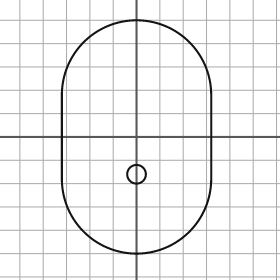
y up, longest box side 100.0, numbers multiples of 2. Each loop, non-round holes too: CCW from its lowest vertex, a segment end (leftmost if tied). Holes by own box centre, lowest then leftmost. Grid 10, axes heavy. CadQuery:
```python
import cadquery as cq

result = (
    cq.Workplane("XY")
    .moveTo(-32.0, -18.0)
    .threePointArc((0.0, -50.0), (32.0, -18.0))
    .lineTo(32.0, 18.0)
    .threePointArc((0.0, 50.0), (-32.0, 18.0))
    .close()
    .moveTo(0.0, -16.0)
    .circle(4.0)
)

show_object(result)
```